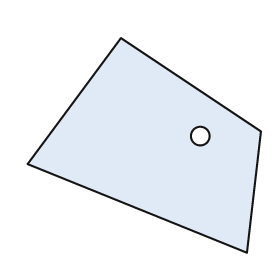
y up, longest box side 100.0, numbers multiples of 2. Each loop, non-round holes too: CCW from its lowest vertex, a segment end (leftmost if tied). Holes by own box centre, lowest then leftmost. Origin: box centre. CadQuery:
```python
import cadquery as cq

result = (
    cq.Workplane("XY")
    .moveTo(44.0, -46.0)
    .lineTo(50.0, 6.0)
    .lineTo(-10.0, 46.0)
    .lineTo(-50.0, -8.0)
    .close()
    .moveTo(24.0, 4.0)
    .circle(4.0)
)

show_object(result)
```